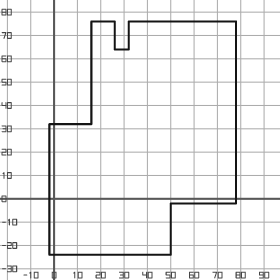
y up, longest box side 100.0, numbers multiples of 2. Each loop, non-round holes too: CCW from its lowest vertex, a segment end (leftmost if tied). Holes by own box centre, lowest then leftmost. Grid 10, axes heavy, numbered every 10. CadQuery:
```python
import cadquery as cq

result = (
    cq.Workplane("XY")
    .moveTo(-2.0, -24.0)
    .lineTo(50.0, -24.0)
    .lineTo(50.0, -2.0)
    .lineTo(78.0, -2.0)
    .lineTo(78.0, 76.0)
    .lineTo(32.0, 76.0)
    .lineTo(32.0, 64.0)
    .lineTo(26.0, 64.0)
    .lineTo(26.0, 76.0)
    .lineTo(16.0, 76.0)
    .lineTo(16.0, 32.0)
    .lineTo(-2.0, 32.0)
    .close()
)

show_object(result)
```